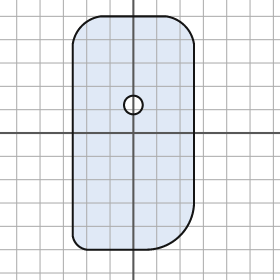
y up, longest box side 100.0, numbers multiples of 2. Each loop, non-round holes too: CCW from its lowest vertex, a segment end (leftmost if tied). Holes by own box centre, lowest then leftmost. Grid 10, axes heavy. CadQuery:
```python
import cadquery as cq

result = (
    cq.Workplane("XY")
    .moveTo(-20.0, -50.0)
    .lineTo(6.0, -50.0)
    .threePointArc((20.0, -44.0), (26.0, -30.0))
    .lineTo(26.0, 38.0)
    .threePointArc((22.0, 46.0), (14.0, 50.0))
    .lineTo(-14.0, 50.0)
    .threePointArc((-22.0, 46.0), (-26.0, 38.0))
    .lineTo(-26.0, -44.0)
    .threePointArc((-24.0, -48.0), (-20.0, -50.0))
    .close()
    .moveTo(0.0, 12.0)
    .circle(4.0)
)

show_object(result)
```